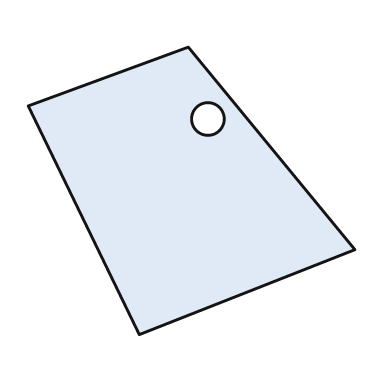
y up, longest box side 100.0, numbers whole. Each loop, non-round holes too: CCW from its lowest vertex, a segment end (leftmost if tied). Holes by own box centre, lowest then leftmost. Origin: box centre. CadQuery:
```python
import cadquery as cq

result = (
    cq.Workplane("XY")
    .moveTo(-16.0, -44.0)
    .lineTo(50.0, -18.0)
    .lineTo(-1.0, 44.0)
    .lineTo(-50.0, 26.0)
    .close()
    .moveTo(5.0, 22.0)
    .circle(5.0)
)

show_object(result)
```